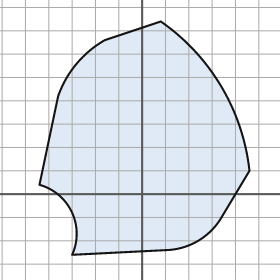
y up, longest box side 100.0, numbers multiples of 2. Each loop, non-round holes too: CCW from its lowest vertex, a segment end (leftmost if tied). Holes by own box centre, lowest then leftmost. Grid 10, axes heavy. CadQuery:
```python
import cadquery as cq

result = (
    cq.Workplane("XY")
    .moveTo(-30.0, -26.0)
    .lineTo(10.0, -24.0)
    .threePointArc((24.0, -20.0), (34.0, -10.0))
    .lineTo(46.0, 10.0)
    .threePointArc((34.0, 46.0), (8.0, 74.0))
    .lineTo(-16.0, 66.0)
    .threePointArc((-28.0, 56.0), (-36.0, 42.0))
    .lineTo(-44.0, 4.0)
    .threePointArc((-30.0, -8.0), (-30.0, -26.0))
    .close()
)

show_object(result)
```